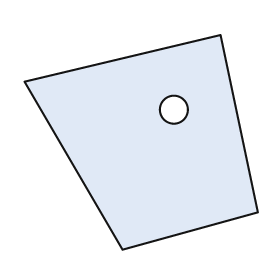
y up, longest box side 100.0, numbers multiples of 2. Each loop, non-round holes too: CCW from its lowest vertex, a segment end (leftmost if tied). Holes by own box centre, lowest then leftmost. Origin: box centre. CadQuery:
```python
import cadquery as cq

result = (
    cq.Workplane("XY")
    .moveTo(-8.0, -46.0)
    .lineTo(50.0, -30.0)
    .lineTo(34.0, 46.0)
    .lineTo(-50.0, 26.0)
    .close()
    .moveTo(14.0, 14.0)
    .circle(6.0)
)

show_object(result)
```